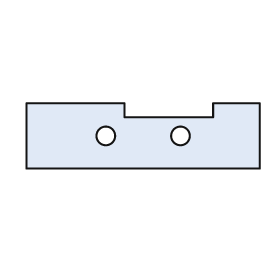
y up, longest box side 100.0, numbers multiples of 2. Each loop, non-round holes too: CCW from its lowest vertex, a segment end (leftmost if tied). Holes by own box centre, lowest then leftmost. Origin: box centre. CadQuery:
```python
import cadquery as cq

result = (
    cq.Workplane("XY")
    .moveTo(-50.0, -14.0)
    .lineTo(50.0, -14.0)
    .lineTo(50.0, 14.0)
    .lineTo(30.0, 14.0)
    .lineTo(30.0, 8.0)
    .lineTo(-8.0, 8.0)
    .lineTo(-8.0, 14.0)
    .lineTo(-50.0, 14.0)
    .close()
    .moveTo(-16.0, 0.0)
    .circle(4.0)
    .moveTo(16.0, 0.0)
    .circle(4.0)
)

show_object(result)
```